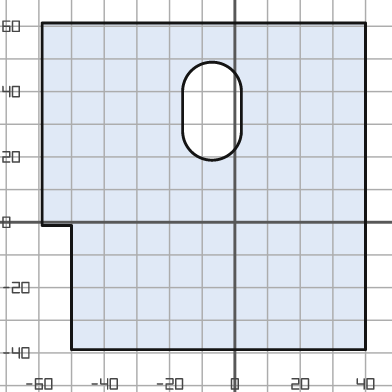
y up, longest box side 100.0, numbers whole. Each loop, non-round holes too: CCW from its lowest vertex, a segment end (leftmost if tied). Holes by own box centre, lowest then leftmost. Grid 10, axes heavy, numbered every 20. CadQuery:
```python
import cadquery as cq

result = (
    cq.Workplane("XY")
    .moveTo(-50.0, -39.0)
    .lineTo(40.0, -39.0)
    .lineTo(40.0, 61.0)
    .lineTo(-59.0, 61.0)
    .lineTo(-59.0, -1.0)
    .lineTo(-50.0, -1.0)
    .close()
    .moveTo(-16.0, 28.0)
    .threePointArc((-7.0, 19.0), (2.0, 28.0))
    .lineTo(2.0, 40.0)
    .threePointArc((-7.0, 49.0), (-16.0, 40.0))
    .close()
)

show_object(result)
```